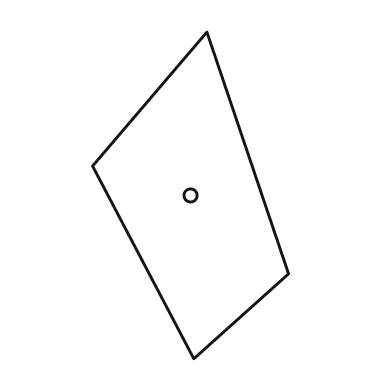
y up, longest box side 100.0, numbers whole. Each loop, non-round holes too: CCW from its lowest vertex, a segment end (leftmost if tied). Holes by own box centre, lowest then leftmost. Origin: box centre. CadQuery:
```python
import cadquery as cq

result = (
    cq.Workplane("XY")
    .moveTo(1.0, -50.0)
    .lineTo(30.0, -24.0)
    .lineTo(5.0, 50.0)
    .lineTo(-30.0, 9.0)
    .close()
    .moveTo(0.0, 0.0)
    .circle(2.0)
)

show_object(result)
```